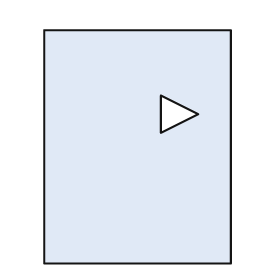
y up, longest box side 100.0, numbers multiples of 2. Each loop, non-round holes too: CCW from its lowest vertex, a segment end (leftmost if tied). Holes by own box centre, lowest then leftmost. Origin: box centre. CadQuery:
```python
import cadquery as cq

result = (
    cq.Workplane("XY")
    .moveTo(-40.0, -50.0)
    .lineTo(40.0, -50.0)
    .lineTo(40.0, 50.0)
    .lineTo(-40.0, 50.0)
    .close()
    .moveTo(10.0, 6.0)
    .lineTo(26.0, 14.0)
    .lineTo(10.0, 22.0)
    .close()
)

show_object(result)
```